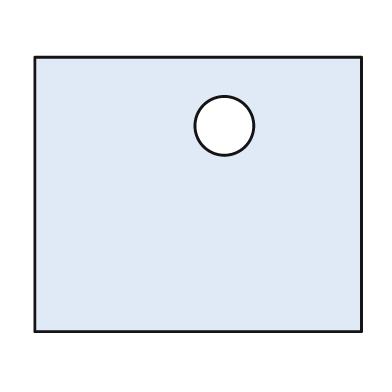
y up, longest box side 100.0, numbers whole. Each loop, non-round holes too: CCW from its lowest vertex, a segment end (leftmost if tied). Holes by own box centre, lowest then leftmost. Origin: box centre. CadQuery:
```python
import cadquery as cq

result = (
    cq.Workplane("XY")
    .moveTo(-50.0, -42.0)
    .lineTo(50.0, -42.0)
    .lineTo(50.0, 42.0)
    .lineTo(-50.0, 42.0)
    .close()
    .moveTo(8.0, 21.0)
    .circle(9.0)
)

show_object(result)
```